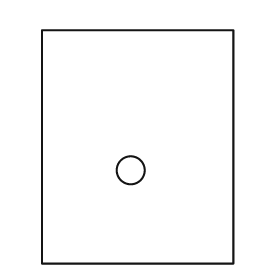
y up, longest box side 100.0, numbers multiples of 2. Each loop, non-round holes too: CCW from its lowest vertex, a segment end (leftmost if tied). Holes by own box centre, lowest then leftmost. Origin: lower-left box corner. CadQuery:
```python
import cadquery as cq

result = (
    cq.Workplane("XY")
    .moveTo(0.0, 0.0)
    .lineTo(82.0, 0.0)
    .lineTo(82.0, 100.0)
    .lineTo(0.0, 100.0)
    .close()
    .moveTo(38.0, 40.0)
    .circle(6.0)
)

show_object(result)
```